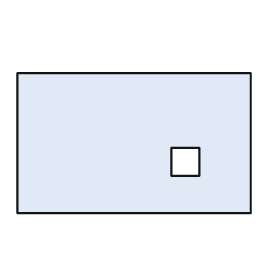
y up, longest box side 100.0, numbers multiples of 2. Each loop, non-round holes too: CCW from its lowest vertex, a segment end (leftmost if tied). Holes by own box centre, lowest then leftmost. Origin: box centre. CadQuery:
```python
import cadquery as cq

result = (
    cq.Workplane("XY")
    .moveTo(-50.0, -30.0)
    .lineTo(50.0, -30.0)
    .lineTo(50.0, 30.0)
    .lineTo(-50.0, 30.0)
    .close()
    .moveTo(16.0, -14.0)
    .lineTo(28.0, -14.0)
    .lineTo(28.0, -2.0)
    .lineTo(16.0, -2.0)
    .close()
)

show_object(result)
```